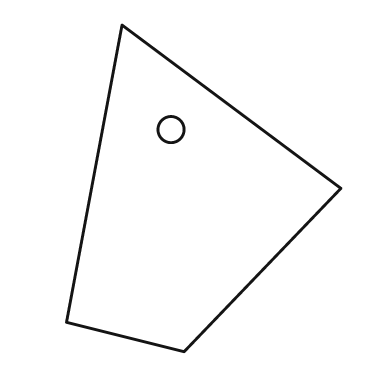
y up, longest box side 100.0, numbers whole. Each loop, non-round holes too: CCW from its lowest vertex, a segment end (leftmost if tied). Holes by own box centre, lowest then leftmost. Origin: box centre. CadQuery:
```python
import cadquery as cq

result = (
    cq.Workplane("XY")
    .moveTo(-6.0, -50.0)
    .lineTo(42.0, 0.0)
    .lineTo(-25.0, 50.0)
    .lineTo(-42.0, -41.0)
    .close()
    .moveTo(-10.0, 18.0)
    .circle(4.0)
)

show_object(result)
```